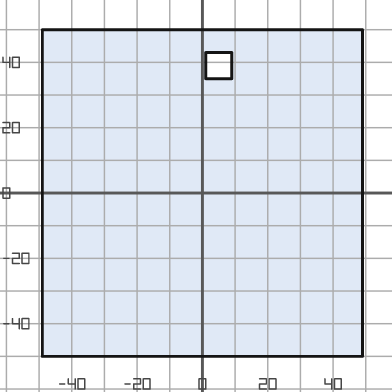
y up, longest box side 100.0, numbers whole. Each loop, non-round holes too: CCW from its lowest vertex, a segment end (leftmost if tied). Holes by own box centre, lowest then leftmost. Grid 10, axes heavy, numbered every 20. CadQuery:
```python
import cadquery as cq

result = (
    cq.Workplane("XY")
    .moveTo(-49.0, -50.0)
    .lineTo(49.0, -50.0)
    .lineTo(49.0, 50.0)
    .lineTo(-49.0, 50.0)
    .close()
    .moveTo(1.0, 35.0)
    .lineTo(9.0, 35.0)
    .lineTo(9.0, 43.0)
    .lineTo(1.0, 43.0)
    .close()
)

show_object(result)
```